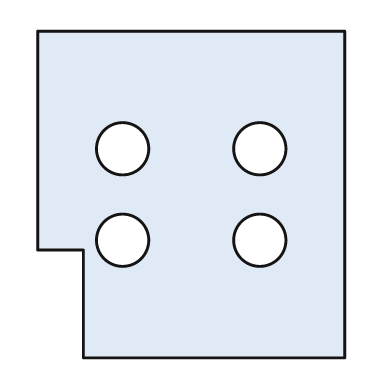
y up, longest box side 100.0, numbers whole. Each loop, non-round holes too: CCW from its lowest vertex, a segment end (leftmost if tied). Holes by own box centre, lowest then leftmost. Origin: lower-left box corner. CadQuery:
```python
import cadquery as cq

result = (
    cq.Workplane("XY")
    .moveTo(14.0, 0.0)
    .lineTo(94.0, 0.0)
    .lineTo(94.0, 100.0)
    .lineTo(0.0, 100.0)
    .lineTo(0.0, 33.0)
    .lineTo(14.0, 33.0)
    .close()
    .moveTo(26.0, 36.0)
    .circle(8.0)
    .moveTo(68.0, 36.0)
    .circle(8.0)
    .moveTo(26.0, 64.0)
    .circle(8.0)
    .moveTo(68.0, 64.0)
    .circle(8.0)
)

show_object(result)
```